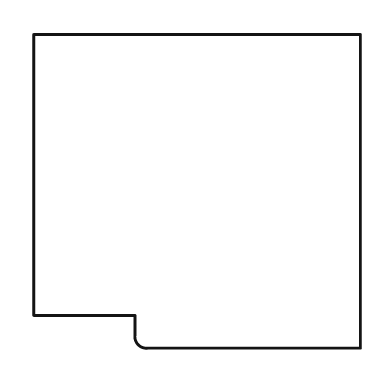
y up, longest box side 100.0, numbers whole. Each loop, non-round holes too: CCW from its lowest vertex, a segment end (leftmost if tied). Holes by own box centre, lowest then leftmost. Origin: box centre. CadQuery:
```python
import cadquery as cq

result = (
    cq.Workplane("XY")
    .moveTo(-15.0, -48.0)
    .lineTo(50.0, -48.0)
    .lineTo(50.0, 48.0)
    .lineTo(-50.0, 48.0)
    .lineTo(-50.0, -38.0)
    .lineTo(-19.0, -38.0)
    .lineTo(-19.0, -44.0)
    .threePointArc((-18.0, -47.0), (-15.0, -48.0))
    .close()
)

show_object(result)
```